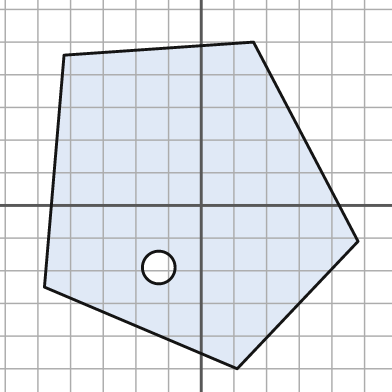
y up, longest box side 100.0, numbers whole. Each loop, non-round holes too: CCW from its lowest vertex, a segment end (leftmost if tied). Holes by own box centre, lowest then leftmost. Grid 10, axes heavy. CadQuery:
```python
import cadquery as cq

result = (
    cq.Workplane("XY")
    .moveTo(11.0, -50.0)
    .lineTo(48.0, -11.0)
    .lineTo(16.0, 50.0)
    .lineTo(-42.0, 46.0)
    .lineTo(-48.0, -25.0)
    .close()
    .moveTo(-13.0, -19.0)
    .circle(5.0)
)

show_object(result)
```